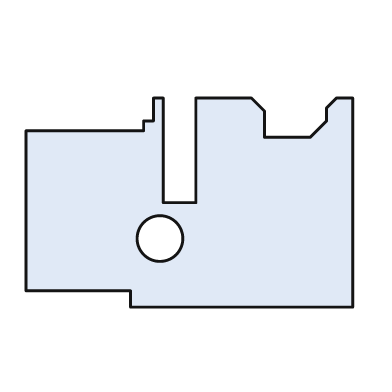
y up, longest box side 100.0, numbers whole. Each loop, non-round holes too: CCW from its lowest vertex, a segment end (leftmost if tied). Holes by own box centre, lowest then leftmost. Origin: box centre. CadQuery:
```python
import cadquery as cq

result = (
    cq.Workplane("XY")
    .moveTo(-18.0, -32.0)
    .lineTo(50.0, -32.0)
    .lineTo(50.0, 32.0)
    .lineTo(45.0, 32.0)
    .lineTo(42.0, 29.0)
    .lineTo(42.0, 25.0)
    .lineTo(37.0, 20.0)
    .lineTo(23.0, 20.0)
    .lineTo(23.0, 28.0)
    .lineTo(19.0, 32.0)
    .lineTo(2.0, 32.0)
    .lineTo(2.0, 0.0)
    .lineTo(-8.0, 0.0)
    .lineTo(-8.0, 32.0)
    .lineTo(-11.0, 32.0)
    .lineTo(-11.0, 25.0)
    .lineTo(-14.0, 25.0)
    .lineTo(-14.0, 22.0)
    .lineTo(-50.0, 22.0)
    .lineTo(-50.0, -27.0)
    .lineTo(-18.0, -27.0)
    .close()
    .moveTo(-9.0, -11.0)
    .circle(7.0)
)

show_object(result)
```